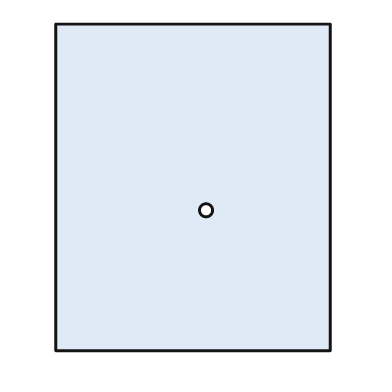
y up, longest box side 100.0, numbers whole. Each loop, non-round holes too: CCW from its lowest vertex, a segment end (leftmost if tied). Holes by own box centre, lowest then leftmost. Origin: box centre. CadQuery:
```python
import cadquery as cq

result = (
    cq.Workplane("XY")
    .moveTo(-42.0, -50.0)
    .lineTo(42.0, -50.0)
    .lineTo(42.0, 50.0)
    .lineTo(-42.0, 50.0)
    .close()
    .moveTo(4.0, -7.0)
    .circle(2.0)
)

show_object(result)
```